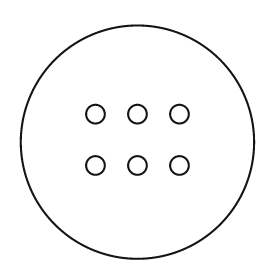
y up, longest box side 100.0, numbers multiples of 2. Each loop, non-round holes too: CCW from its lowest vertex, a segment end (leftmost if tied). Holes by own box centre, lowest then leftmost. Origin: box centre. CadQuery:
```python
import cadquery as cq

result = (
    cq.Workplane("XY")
    .moveTo(0.0, 0.0)
    .circle(50.0)
    .moveTo(-18.0, -10.0)
    .circle(4.0)
    .moveTo(0.0, -10.0)
    .circle(4.0)
    .moveTo(18.0, -10.0)
    .circle(4.0)
    .moveTo(-18.0, 12.0)
    .circle(4.0)
    .moveTo(0.0, 12.0)
    .circle(4.0)
    .moveTo(18.0, 12.0)
    .circle(4.0)
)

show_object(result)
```